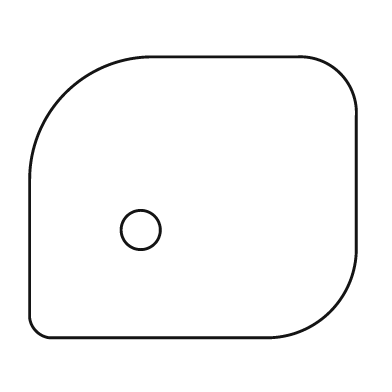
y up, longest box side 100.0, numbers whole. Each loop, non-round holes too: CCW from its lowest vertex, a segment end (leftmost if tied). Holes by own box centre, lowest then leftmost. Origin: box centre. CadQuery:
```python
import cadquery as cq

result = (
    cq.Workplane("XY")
    .moveTo(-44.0, -43.0)
    .lineTo(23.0, -43.0)
    .threePointArc((42.0, -35.0), (50.0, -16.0))
    .lineTo(50.0, 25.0)
    .threePointArc((45.0, 38.0), (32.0, 43.0))
    .lineTo(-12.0, 43.0)
    .threePointArc((-39.0, 32.0), (-50.0, 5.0))
    .lineTo(-50.0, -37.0)
    .threePointArc((-48.0, -41.0), (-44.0, -43.0))
    .close()
    .moveTo(-16.0, -10.0)
    .circle(6.0)
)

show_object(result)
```